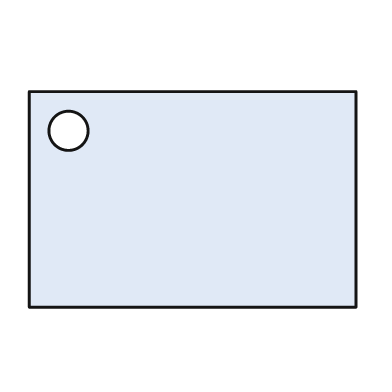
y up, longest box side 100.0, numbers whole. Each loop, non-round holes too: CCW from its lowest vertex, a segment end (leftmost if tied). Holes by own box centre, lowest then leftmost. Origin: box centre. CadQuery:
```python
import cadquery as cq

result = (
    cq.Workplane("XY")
    .moveTo(-50.0, -33.0)
    .lineTo(50.0, -33.0)
    .lineTo(50.0, 33.0)
    .lineTo(-50.0, 33.0)
    .close()
    .moveTo(-38.0, 21.0)
    .circle(6.0)
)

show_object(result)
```